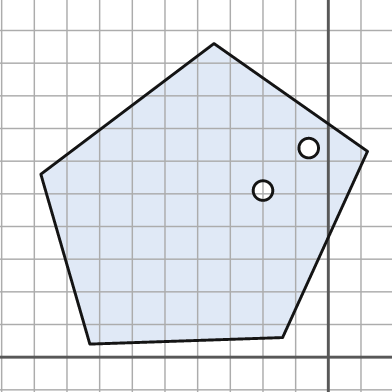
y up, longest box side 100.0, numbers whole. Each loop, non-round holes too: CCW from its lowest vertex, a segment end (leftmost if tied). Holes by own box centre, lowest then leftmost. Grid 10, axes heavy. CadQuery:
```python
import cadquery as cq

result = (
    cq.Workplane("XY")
    .moveTo(-73.0, 4.0)
    .lineTo(-14.0, 6.0)
    .lineTo(12.0, 63.0)
    .lineTo(-35.0, 96.0)
    .lineTo(-88.0, 56.0)
    .close()
    .moveTo(-20.0, 51.0)
    .circle(3.0)
    .moveTo(-6.0, 64.0)
    .circle(3.0)
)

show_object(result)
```